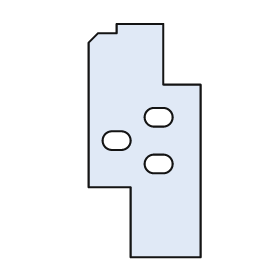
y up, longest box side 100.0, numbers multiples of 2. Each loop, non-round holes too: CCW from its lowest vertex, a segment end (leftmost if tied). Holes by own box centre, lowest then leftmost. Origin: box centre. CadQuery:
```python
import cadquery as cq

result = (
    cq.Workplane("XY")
    .moveTo(-6.0, -50.0)
    .lineTo(24.0, -50.0)
    .lineTo(24.0, 24.0)
    .lineTo(8.0, 24.0)
    .lineTo(8.0, 50.0)
    .lineTo(-12.0, 50.0)
    .lineTo(-12.0, 46.0)
    .lineTo(-20.0, 46.0)
    .lineTo(-24.0, 42.0)
    .lineTo(-24.0, -20.0)
    .lineTo(-6.0, -20.0)
    .close()
    .moveTo(4.0, -14.0)
    .lineTo(8.0, -14.0)
    .threePointArc((12.0, -10.0), (8.0, -6.0))
    .lineTo(4.0, -6.0)
    .threePointArc((0.0, -10.0), (4.0, -14.0))
    .close()
    .moveTo(-14.0, -4.0)
    .lineTo(-10.0, -4.0)
    .threePointArc((-6.0, 0.0), (-10.0, 4.0))
    .lineTo(-14.0, 4.0)
    .threePointArc((-18.0, 0.0), (-14.0, -4.0))
    .close()
    .moveTo(4.0, 6.0)
    .lineTo(8.0, 6.0)
    .threePointArc((12.0, 10.0), (8.0, 14.0))
    .lineTo(4.0, 14.0)
    .threePointArc((0.0, 10.0), (4.0, 6.0))
    .close()
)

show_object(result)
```